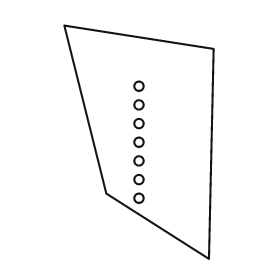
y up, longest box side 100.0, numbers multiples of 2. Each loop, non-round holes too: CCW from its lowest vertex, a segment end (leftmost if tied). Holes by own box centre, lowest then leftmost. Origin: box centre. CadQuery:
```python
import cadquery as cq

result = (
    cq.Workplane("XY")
    .moveTo(30.0, -50.0)
    .lineTo(32.0, 40.0)
    .lineTo(-32.0, 50.0)
    .lineTo(-14.0, -22.0)
    .close()
    .moveTo(0.0, -24.0)
    .circle(2.0)
    .moveTo(0.0, -16.0)
    .circle(2.0)
    .moveTo(0.0, -8.0)
    .circle(2.0)
    .moveTo(0.0, 0.0)
    .circle(2.0)
    .moveTo(0.0, 8.0)
    .circle(2.0)
    .moveTo(0.0, 16.0)
    .circle(2.0)
    .moveTo(0.0, 24.0)
    .circle(2.0)
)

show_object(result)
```